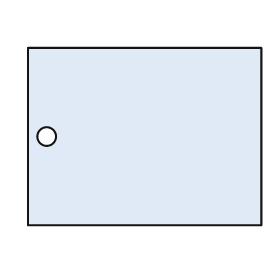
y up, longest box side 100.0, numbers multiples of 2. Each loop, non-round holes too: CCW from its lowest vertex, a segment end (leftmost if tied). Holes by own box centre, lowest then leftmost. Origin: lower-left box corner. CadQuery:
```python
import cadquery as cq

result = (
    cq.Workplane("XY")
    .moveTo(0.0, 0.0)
    .lineTo(100.0, 0.0)
    .lineTo(100.0, 76.0)
    .lineTo(0.0, 76.0)
    .close()
    .moveTo(8.0, 38.0)
    .circle(4.0)
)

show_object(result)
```